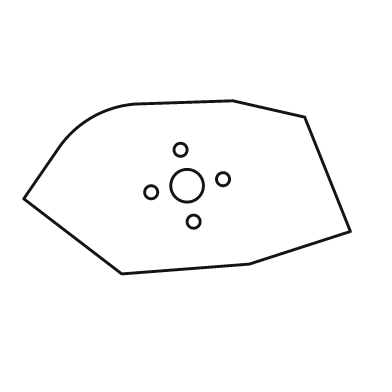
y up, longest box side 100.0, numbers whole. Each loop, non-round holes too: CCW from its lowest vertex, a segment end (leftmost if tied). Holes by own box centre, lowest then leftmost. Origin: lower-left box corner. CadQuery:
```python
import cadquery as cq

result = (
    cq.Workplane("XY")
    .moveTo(30.0, 0.0)
    .lineTo(69.0, 3.0)
    .lineTo(100.0, 13.0)
    .lineTo(86.0, 48.0)
    .lineTo(64.0, 53.0)
    .lineTo(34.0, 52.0)
    .threePointArc((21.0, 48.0), (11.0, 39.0))
    .lineTo(0.0, 23.0)
    .close()
    .moveTo(52.0, 16.0)
    .circle(2.0)
    .moveTo(39.0, 25.0)
    .circle(2.0)
    .moveTo(50.0, 27.0)
    .circle(5.0)
    .moveTo(61.0, 29.0)
    .circle(2.0)
    .moveTo(48.0, 38.0)
    .circle(2.0)
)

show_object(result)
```